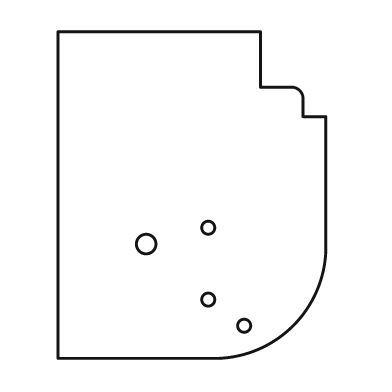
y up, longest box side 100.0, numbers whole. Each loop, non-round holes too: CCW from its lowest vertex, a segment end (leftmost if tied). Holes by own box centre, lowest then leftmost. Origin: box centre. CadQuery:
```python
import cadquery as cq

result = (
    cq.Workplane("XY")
    .moveTo(-41.0, -50.0)
    .lineTo(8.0, -50.0)
    .threePointArc((31.0, -40.0), (41.0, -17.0))
    .lineTo(41.0, 24.0)
    .lineTo(34.0, 24.0)
    .lineTo(34.0, 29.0)
    .threePointArc((33.0, 32.0), (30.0, 33.0))
    .lineTo(21.0, 33.0)
    .lineTo(21.0, 50.0)
    .lineTo(-41.0, 50.0)
    .close()
    .moveTo(16.0, -40.0)
    .circle(2.0)
    .moveTo(5.0, -32.0)
    .circle(2.0)
    .moveTo(-14.0, -15.0)
    .circle(3.0)
    .moveTo(5.0, -10.0)
    .circle(2.0)
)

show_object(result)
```